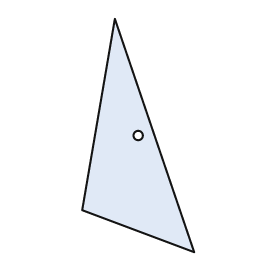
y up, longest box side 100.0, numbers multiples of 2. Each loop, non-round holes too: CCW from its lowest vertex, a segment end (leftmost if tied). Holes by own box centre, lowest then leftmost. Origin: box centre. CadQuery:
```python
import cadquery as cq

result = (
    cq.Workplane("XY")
    .moveTo(24.0, -50.0)
    .lineTo(-10.0, 50.0)
    .lineTo(-24.0, -32.0)
    .close()
    .moveTo(0.0, 0.0)
    .circle(2.0)
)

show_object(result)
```